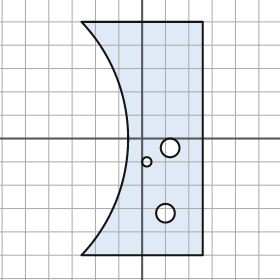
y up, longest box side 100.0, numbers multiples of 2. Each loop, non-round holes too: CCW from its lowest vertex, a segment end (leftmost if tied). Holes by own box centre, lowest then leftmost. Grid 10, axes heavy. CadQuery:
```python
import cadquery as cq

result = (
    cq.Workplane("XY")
    .moveTo(-26.0, -50.0)
    .lineTo(26.0, -50.0)
    .lineTo(26.0, 50.0)
    .lineTo(-26.0, 50.0)
    .threePointArc((-6.0, 0.0), (-26.0, -50.0))
    .close()
    .moveTo(10.0, -32.0)
    .circle(4.0)
    .moveTo(2.0, -10.0)
    .circle(2.0)
    .moveTo(12.0, -4.0)
    .circle(4.0)
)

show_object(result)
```